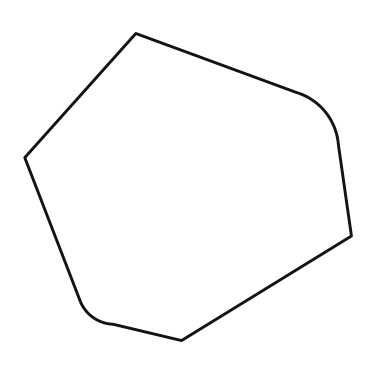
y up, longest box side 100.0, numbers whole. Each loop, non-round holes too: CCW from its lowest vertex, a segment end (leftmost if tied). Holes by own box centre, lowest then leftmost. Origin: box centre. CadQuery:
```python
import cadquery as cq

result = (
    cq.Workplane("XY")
    .moveTo(-2.0, -47.0)
    .lineTo(50.0, -15.0)
    .lineTo(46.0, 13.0)
    .threePointArc((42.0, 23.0), (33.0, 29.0))
    .lineTo(-16.0, 47.0)
    .lineTo(-50.0, 9.0)
    .lineTo(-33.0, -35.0)
    .threePointArc((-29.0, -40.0), (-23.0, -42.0))
    .close()
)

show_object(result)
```